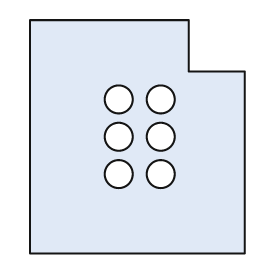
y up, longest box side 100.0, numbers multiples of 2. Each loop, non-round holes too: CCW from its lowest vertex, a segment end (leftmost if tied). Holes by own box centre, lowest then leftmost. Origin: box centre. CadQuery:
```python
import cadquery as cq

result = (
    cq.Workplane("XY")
    .moveTo(-46.0, -50.0)
    .lineTo(46.0, -50.0)
    .lineTo(46.0, 28.0)
    .lineTo(22.0, 28.0)
    .lineTo(22.0, 50.0)
    .lineTo(-46.0, 50.0)
    .close()
    .moveTo(-8.0, -16.0)
    .circle(6.0)
    .moveTo(10.0, -16.0)
    .circle(6.0)
    .moveTo(-8.0, 0.0)
    .circle(6.0)
    .moveTo(10.0, 0.0)
    .circle(6.0)
    .moveTo(-8.0, 16.0)
    .circle(6.0)
    .moveTo(10.0, 16.0)
    .circle(6.0)
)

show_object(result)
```